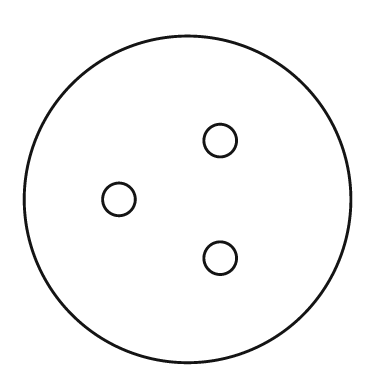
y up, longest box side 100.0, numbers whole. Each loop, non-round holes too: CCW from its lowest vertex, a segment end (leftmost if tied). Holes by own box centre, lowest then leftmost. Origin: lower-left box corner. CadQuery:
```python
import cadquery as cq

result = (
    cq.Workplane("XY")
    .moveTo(50.0, 50.0)
    .circle(50.0)
    .moveTo(60.0, 32.0)
    .circle(5.0)
    .moveTo(29.0, 50.0)
    .circle(5.0)
    .moveTo(60.0, 68.0)
    .circle(5.0)
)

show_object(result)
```